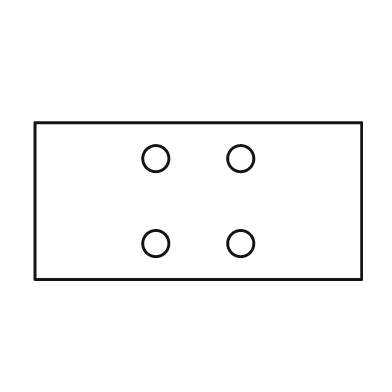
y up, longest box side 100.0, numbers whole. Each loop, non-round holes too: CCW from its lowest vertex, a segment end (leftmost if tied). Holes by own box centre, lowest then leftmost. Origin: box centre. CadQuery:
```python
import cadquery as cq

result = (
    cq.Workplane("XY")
    .moveTo(-50.0, -24.0)
    .lineTo(50.0, -24.0)
    .lineTo(50.0, 24.0)
    .lineTo(-50.0, 24.0)
    .close()
    .moveTo(-13.0, -13.0)
    .circle(4.0)
    .moveTo(13.0, -13.0)
    .circle(4.0)
    .moveTo(-13.0, 13.0)
    .circle(4.0)
    .moveTo(13.0, 13.0)
    .circle(4.0)
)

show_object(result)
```